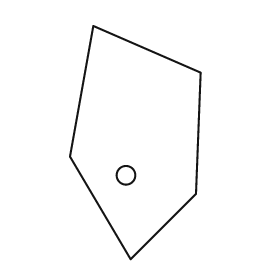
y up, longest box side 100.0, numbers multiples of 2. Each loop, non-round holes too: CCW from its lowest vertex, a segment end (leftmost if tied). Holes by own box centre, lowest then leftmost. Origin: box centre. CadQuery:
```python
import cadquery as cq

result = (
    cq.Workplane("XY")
    .moveTo(-2.0, -50.0)
    .lineTo(26.0, -22.0)
    .lineTo(28.0, 30.0)
    .lineTo(-18.0, 50.0)
    .lineTo(-28.0, -6.0)
    .close()
    .moveTo(-4.0, -14.0)
    .circle(4.0)
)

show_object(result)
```